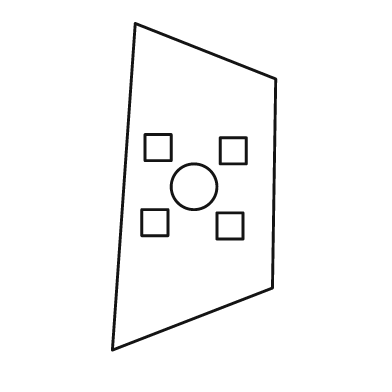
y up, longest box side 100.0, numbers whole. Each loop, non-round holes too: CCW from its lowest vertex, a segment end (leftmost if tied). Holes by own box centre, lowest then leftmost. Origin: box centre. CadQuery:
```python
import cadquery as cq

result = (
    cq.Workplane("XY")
    .moveTo(-25.0, -50.0)
    .lineTo(24.0, -31.0)
    .lineTo(25.0, 33.0)
    .lineTo(-18.0, 50.0)
    .close()
    .moveTo(7.0, -16.0)
    .lineTo(15.0, -16.0)
    .lineTo(15.0, -8.0)
    .lineTo(7.0, -8.0)
    .close()
    .moveTo(-16.0, -15.0)
    .lineTo(-8.0, -15.0)
    .lineTo(-8.0, -7.0)
    .lineTo(-16.0, -7.0)
    .close()
    .moveTo(0.0, 0.0)
    .circle(7.0)
    .moveTo(8.0, 7.0)
    .lineTo(16.0, 7.0)
    .lineTo(16.0, 15.0)
    .lineTo(8.0, 15.0)
    .close()
    .moveTo(-15.0, 8.0)
    .lineTo(-7.0, 8.0)
    .lineTo(-7.0, 16.0)
    .lineTo(-15.0, 16.0)
    .close()
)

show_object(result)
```